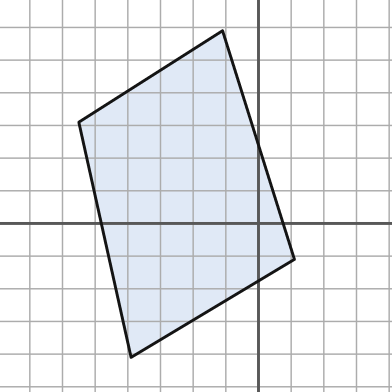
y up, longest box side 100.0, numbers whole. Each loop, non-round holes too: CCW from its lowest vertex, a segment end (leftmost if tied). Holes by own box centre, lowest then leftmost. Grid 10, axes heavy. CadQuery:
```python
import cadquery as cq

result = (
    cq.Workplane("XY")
    .moveTo(-39.0, -41.0)
    .lineTo(11.0, -11.0)
    .lineTo(-11.0, 59.0)
    .lineTo(-55.0, 31.0)
    .close()
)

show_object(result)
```